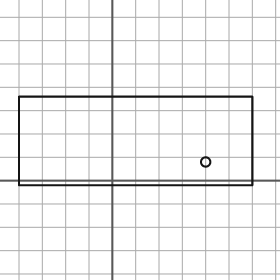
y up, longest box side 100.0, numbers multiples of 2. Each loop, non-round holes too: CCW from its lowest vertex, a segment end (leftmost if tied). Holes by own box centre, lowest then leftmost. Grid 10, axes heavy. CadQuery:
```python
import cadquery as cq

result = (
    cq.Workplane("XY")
    .moveTo(-40.0, -2.0)
    .lineTo(60.0, -2.0)
    .lineTo(60.0, 36.0)
    .lineTo(-40.0, 36.0)
    .close()
    .moveTo(40.0, 8.0)
    .circle(2.0)
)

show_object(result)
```